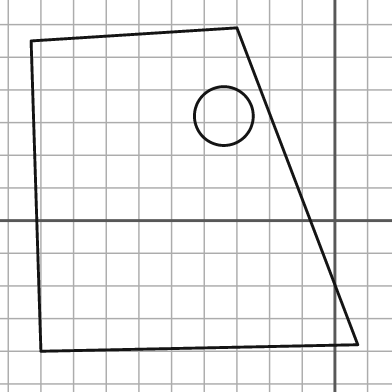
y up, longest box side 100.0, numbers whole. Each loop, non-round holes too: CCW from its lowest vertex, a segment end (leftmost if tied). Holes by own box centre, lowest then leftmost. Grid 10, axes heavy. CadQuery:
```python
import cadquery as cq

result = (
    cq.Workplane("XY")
    .moveTo(-90.0, -40.0)
    .lineTo(7.0, -38.0)
    .lineTo(-30.0, 59.0)
    .lineTo(-93.0, 55.0)
    .close()
    .moveTo(-34.0, 32.0)
    .circle(9.0)
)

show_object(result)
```